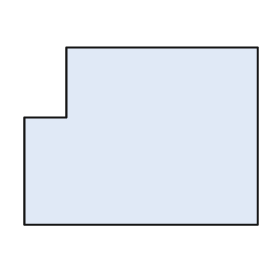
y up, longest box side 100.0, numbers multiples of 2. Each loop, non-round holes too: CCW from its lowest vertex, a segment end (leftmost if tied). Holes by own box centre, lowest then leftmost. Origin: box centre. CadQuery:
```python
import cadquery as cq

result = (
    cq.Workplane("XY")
    .moveTo(-50.0, -38.0)
    .lineTo(50.0, -38.0)
    .lineTo(50.0, 38.0)
    .lineTo(-32.0, 38.0)
    .lineTo(-32.0, 8.0)
    .lineTo(-50.0, 8.0)
    .close()
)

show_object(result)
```